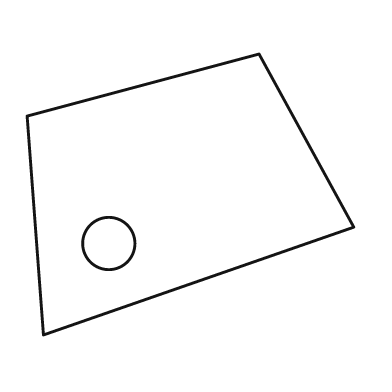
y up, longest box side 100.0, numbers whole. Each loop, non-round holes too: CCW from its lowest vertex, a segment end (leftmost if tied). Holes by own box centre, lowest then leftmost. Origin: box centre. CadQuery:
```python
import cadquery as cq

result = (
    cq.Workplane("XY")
    .moveTo(-45.0, -43.0)
    .lineTo(50.0, -10.0)
    .lineTo(21.0, 43.0)
    .lineTo(-50.0, 24.0)
    .close()
    .moveTo(-25.0, -15.0)
    .circle(8.0)
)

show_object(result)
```